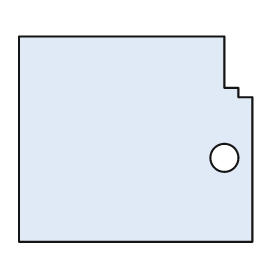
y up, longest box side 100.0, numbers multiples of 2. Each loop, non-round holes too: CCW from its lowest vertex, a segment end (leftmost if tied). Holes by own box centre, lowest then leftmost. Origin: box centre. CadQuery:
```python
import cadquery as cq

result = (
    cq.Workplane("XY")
    .moveTo(-50.0, -44.0)
    .lineTo(50.0, -44.0)
    .lineTo(50.0, 18.0)
    .lineTo(44.0, 18.0)
    .lineTo(44.0, 22.0)
    .lineTo(38.0, 22.0)
    .lineTo(38.0, 44.0)
    .lineTo(-50.0, 44.0)
    .close()
    .moveTo(38.0, -8.0)
    .circle(6.0)
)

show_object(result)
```